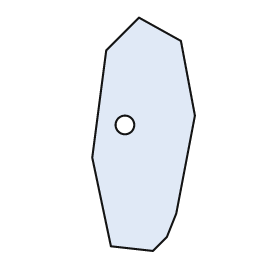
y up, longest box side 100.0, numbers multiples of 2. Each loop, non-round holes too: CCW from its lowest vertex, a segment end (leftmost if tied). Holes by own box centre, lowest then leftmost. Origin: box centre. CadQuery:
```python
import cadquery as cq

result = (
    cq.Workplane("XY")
    .moveTo(4.0, -50.0)
    .lineTo(10.0, -44.0)
    .lineTo(14.0, -34.0)
    .lineTo(22.0, 8.0)
    .lineTo(16.0, 40.0)
    .lineTo(-2.0, 50.0)
    .lineTo(-16.0, 36.0)
    .lineTo(-22.0, -10.0)
    .lineTo(-14.0, -48.0)
    .close()
    .moveTo(-8.0, 4.0)
    .circle(4.0)
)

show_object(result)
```